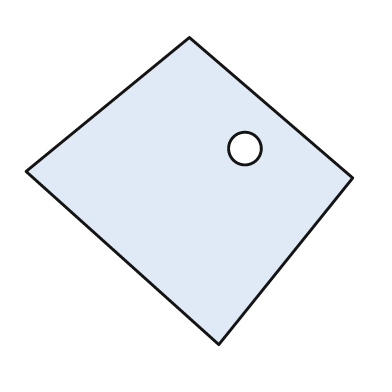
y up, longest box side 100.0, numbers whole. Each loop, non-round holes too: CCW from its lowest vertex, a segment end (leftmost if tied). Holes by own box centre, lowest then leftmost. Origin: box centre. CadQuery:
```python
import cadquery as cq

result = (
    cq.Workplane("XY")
    .moveTo(9.0, -47.0)
    .lineTo(50.0, 4.0)
    .lineTo(0.0, 47.0)
    .lineTo(-50.0, 6.0)
    .close()
    .moveTo(17.0, 13.0)
    .circle(5.0)
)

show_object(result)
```